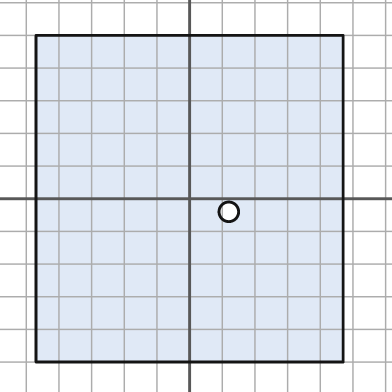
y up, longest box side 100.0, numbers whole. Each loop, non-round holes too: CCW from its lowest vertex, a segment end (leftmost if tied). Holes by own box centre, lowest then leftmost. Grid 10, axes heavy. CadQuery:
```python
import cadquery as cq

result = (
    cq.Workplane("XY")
    .moveTo(-47.0, -50.0)
    .lineTo(47.0, -50.0)
    .lineTo(47.0, 50.0)
    .lineTo(-47.0, 50.0)
    .close()
    .moveTo(12.0, -4.0)
    .circle(3.0)
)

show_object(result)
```